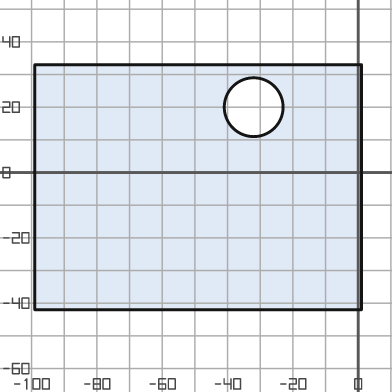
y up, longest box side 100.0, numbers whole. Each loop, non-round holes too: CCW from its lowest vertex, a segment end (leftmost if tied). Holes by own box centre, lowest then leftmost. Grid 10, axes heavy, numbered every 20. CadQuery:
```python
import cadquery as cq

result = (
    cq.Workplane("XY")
    .moveTo(-99.0, -42.0)
    .lineTo(1.0, -42.0)
    .lineTo(1.0, 33.0)
    .lineTo(-99.0, 33.0)
    .close()
    .moveTo(-32.0, 20.0)
    .circle(9.0)
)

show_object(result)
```